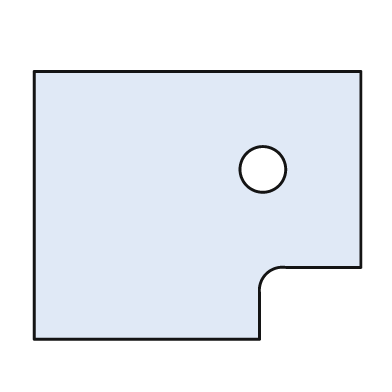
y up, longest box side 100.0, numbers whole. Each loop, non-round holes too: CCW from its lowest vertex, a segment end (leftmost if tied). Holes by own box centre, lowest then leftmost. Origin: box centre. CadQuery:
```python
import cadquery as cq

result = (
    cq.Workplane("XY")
    .moveTo(-50.0, -41.0)
    .lineTo(19.0, -41.0)
    .lineTo(19.0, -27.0)
    .threePointArc((21.0, -21.0), (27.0, -19.0))
    .lineTo(50.0, -19.0)
    .lineTo(50.0, 41.0)
    .lineTo(-50.0, 41.0)
    .close()
    .moveTo(20.0, 11.0)
    .circle(7.0)
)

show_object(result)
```